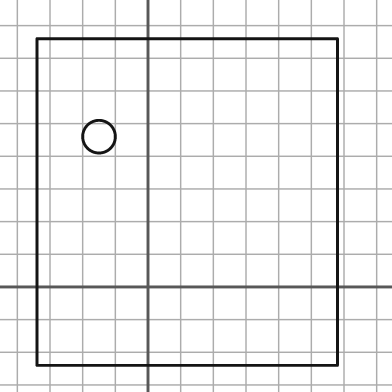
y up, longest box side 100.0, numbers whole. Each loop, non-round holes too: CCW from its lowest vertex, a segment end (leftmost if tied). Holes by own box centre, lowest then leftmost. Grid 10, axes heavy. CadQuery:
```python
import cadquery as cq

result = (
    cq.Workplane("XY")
    .moveTo(-34.0, -24.0)
    .lineTo(58.0, -24.0)
    .lineTo(58.0, 76.0)
    .lineTo(-34.0, 76.0)
    .close()
    .moveTo(-15.0, 46.0)
    .circle(5.0)
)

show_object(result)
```